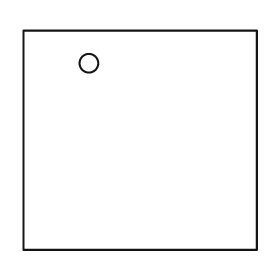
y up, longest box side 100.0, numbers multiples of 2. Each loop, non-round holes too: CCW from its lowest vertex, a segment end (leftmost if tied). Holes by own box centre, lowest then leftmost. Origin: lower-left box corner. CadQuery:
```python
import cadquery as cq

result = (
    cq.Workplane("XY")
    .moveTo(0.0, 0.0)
    .lineTo(100.0, 0.0)
    .lineTo(100.0, 94.0)
    .lineTo(0.0, 94.0)
    .close()
    .moveTo(28.0, 80.0)
    .circle(4.0)
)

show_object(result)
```